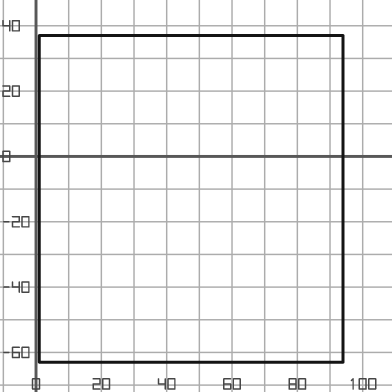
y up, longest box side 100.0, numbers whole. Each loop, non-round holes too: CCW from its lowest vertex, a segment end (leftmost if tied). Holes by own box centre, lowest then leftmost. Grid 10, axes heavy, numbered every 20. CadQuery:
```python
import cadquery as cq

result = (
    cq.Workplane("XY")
    .moveTo(1.0, -63.0)
    .lineTo(94.0, -63.0)
    .lineTo(94.0, 37.0)
    .lineTo(1.0, 37.0)
    .close()
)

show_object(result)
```